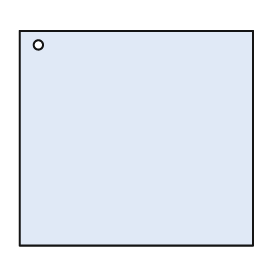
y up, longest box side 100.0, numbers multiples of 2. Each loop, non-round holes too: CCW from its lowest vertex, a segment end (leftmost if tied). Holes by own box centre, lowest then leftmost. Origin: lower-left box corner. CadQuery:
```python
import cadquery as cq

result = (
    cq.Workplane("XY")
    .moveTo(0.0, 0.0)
    .lineTo(100.0, 0.0)
    .lineTo(100.0, 92.0)
    .lineTo(0.0, 92.0)
    .close()
    .moveTo(8.0, 86.0)
    .circle(2.0)
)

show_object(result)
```